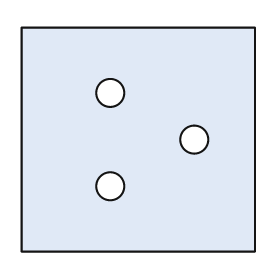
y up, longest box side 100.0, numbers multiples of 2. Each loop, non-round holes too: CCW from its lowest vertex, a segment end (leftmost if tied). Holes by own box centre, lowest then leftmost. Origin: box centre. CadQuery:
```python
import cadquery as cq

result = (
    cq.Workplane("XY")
    .moveTo(-50.0, -48.0)
    .lineTo(50.0, -48.0)
    .lineTo(50.0, 48.0)
    .lineTo(-50.0, 48.0)
    .close()
    .moveTo(-12.0, -20.0)
    .circle(6.0)
    .moveTo(24.0, 0.0)
    .circle(6.0)
    .moveTo(-12.0, 20.0)
    .circle(6.0)
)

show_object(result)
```